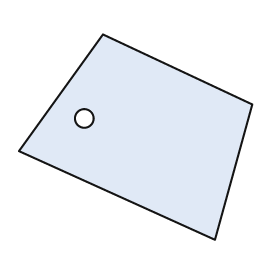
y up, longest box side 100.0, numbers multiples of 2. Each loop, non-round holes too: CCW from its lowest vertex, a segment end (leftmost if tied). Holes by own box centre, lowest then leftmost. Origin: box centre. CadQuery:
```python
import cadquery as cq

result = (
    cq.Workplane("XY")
    .moveTo(34.0, -44.0)
    .lineTo(50.0, 14.0)
    .lineTo(-14.0, 44.0)
    .lineTo(-50.0, -6.0)
    .close()
    .moveTo(-22.0, 8.0)
    .circle(4.0)
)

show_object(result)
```